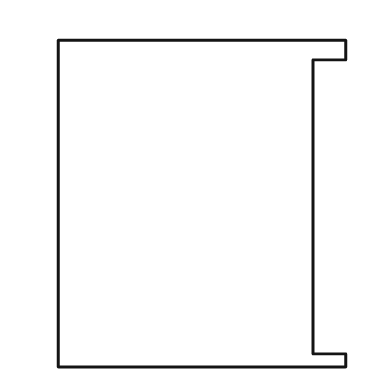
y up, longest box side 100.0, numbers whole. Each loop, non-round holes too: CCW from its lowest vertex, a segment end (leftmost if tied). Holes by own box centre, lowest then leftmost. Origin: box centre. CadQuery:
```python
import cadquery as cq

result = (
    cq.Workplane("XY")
    .moveTo(-44.0, -50.0)
    .lineTo(44.0, -50.0)
    .lineTo(44.0, -46.0)
    .lineTo(34.0, -46.0)
    .lineTo(34.0, 44.0)
    .lineTo(44.0, 44.0)
    .lineTo(44.0, 50.0)
    .lineTo(-44.0, 50.0)
    .close()
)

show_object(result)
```